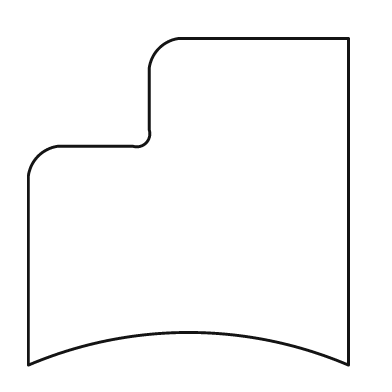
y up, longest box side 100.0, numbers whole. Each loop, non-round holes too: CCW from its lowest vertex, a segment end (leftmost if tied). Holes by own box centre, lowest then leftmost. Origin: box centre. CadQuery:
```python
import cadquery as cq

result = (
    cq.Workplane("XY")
    .moveTo(-49.0, -50.0)
    .threePointArc((0.0, -40.0), (49.0, -50.0))
    .lineTo(49.0, 50.0)
    .lineTo(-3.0, 50.0)
    .threePointArc((-9.0, 47.0), (-12.0, 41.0))
    .lineTo(-12.0, 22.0)
    .threePointArc((-13.0, 18.0), (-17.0, 17.0))
    .lineTo(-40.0, 17.0)
    .threePointArc((-46.0, 14.0), (-49.0, 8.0))
    .close()
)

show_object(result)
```